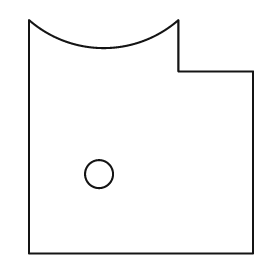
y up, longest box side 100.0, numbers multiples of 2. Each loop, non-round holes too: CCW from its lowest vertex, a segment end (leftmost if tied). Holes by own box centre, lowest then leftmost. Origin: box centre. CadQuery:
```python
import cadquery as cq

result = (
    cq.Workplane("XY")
    .moveTo(-48.0, -50.0)
    .lineTo(48.0, -50.0)
    .lineTo(48.0, 28.0)
    .lineTo(16.0, 28.0)
    .lineTo(16.0, 50.0)
    .threePointArc((-16.0, 38.0), (-48.0, 50.0))
    .close()
    .moveTo(-18.0, -16.0)
    .circle(6.0)
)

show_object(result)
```